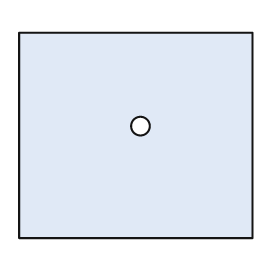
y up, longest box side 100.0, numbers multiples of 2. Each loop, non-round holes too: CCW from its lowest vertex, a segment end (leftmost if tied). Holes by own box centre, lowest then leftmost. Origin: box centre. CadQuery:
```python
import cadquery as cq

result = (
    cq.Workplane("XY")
    .moveTo(-50.0, -44.0)
    .lineTo(50.0, -44.0)
    .lineTo(50.0, 44.0)
    .lineTo(-50.0, 44.0)
    .close()
    .moveTo(2.0, 4.0)
    .circle(4.0)
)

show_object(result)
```